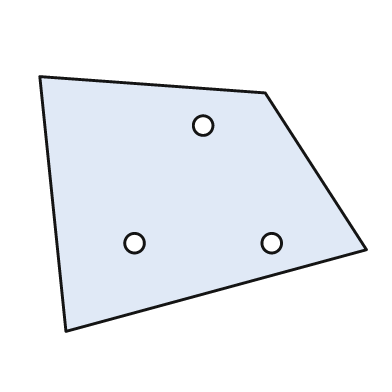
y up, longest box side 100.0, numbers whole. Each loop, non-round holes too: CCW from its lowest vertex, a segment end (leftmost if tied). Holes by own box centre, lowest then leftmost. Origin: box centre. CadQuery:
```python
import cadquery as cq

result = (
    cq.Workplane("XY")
    .moveTo(-42.0, -39.0)
    .lineTo(50.0, -14.0)
    .lineTo(19.0, 34.0)
    .lineTo(-50.0, 39.0)
    .close()
    .moveTo(-21.0, -12.0)
    .circle(3.0)
    .moveTo(21.0, -12.0)
    .circle(3.0)
    .moveTo(0.0, 24.0)
    .circle(3.0)
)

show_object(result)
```